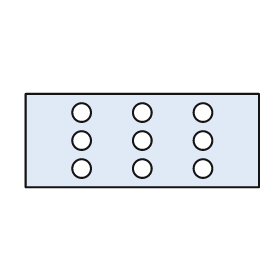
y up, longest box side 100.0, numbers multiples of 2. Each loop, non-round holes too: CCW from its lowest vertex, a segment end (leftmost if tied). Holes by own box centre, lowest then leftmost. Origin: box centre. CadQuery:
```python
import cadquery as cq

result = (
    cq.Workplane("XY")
    .moveTo(-50.0, -20.0)
    .lineTo(50.0, -20.0)
    .lineTo(50.0, 20.0)
    .lineTo(-50.0, 20.0)
    .close()
    .moveTo(-26.0, -12.0)
    .circle(4.0)
    .moveTo(0.0, -12.0)
    .circle(4.0)
    .moveTo(26.0, -12.0)
    .circle(4.0)
    .moveTo(-26.0, 0.0)
    .circle(4.0)
    .moveTo(0.0, 0.0)
    .circle(4.0)
    .moveTo(26.0, 0.0)
    .circle(4.0)
    .moveTo(-26.0, 12.0)
    .circle(4.0)
    .moveTo(0.0, 12.0)
    .circle(4.0)
    .moveTo(26.0, 12.0)
    .circle(4.0)
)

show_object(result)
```